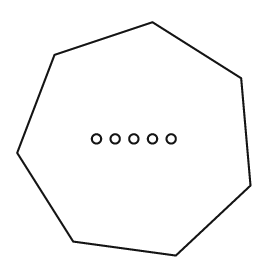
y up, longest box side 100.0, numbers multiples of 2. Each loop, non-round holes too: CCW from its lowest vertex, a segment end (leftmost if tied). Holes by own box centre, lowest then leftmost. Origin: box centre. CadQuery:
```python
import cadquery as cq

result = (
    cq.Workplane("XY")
    .moveTo(18.0, -50.0)
    .lineTo(50.0, -20.0)
    .lineTo(46.0, 26.0)
    .lineTo(8.0, 50.0)
    .lineTo(-34.0, 36.0)
    .lineTo(-50.0, -6.0)
    .lineTo(-26.0, -44.0)
    .close()
    .moveTo(-16.0, 0.0)
    .circle(2.0)
    .moveTo(-8.0, 0.0)
    .circle(2.0)
    .moveTo(0.0, 0.0)
    .circle(2.0)
    .moveTo(8.0, 0.0)
    .circle(2.0)
    .moveTo(16.0, 0.0)
    .circle(2.0)
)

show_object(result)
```